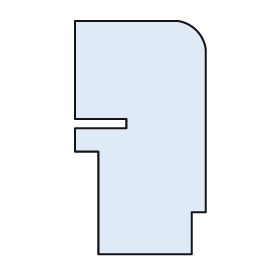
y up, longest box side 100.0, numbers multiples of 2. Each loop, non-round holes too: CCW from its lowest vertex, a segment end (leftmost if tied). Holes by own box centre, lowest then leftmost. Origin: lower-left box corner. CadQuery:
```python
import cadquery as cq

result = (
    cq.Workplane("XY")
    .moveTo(10.0, 0.0)
    .lineTo(50.0, 0.0)
    .lineTo(50.0, 18.0)
    .lineTo(56.0, 18.0)
    .lineTo(56.0, 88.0)
    .threePointArc((52.0, 96.0), (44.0, 100.0))
    .lineTo(0.0, 100.0)
    .lineTo(0.0, 58.0)
    .lineTo(22.0, 58.0)
    .lineTo(22.0, 54.0)
    .lineTo(0.0, 54.0)
    .lineTo(0.0, 44.0)
    .lineTo(10.0, 44.0)
    .close()
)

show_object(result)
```